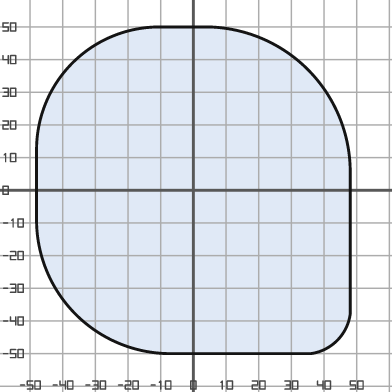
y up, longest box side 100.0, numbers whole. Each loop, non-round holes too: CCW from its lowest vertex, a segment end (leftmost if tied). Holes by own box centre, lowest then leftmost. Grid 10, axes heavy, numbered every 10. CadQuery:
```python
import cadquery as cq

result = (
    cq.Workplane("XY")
    .moveTo(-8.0, -50.0)
    .lineTo(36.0, -50.0)
    .threePointArc((44.0, -46.0), (48.0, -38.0))
    .lineTo(48.0, 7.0)
    .threePointArc((35.0, 37.0), (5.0, 50.0))
    .lineTo(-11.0, 50.0)
    .threePointArc((-37.0, 39.0), (-48.0, 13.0))
    .lineTo(-48.0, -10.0)
    .threePointArc((-36.0, -38.0), (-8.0, -50.0))
    .close()
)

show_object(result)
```